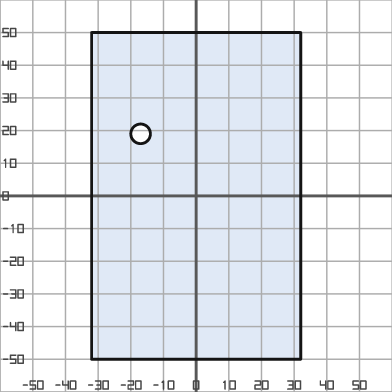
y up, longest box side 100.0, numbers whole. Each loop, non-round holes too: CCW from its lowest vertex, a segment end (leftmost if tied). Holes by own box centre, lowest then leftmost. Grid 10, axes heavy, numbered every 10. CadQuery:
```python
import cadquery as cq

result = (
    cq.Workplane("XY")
    .moveTo(-32.0, -50.0)
    .lineTo(32.0, -50.0)
    .lineTo(32.0, 50.0)
    .lineTo(-32.0, 50.0)
    .close()
    .moveTo(-17.0, 19.0)
    .circle(3.0)
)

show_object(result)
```